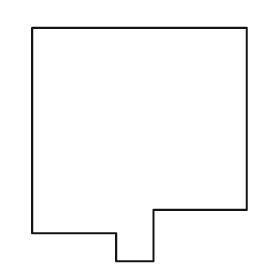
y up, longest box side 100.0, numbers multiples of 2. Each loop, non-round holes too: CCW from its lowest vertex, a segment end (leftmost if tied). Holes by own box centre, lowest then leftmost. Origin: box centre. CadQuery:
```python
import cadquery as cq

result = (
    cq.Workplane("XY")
    .moveTo(-10.0, -50.0)
    .lineTo(6.0, -50.0)
    .lineTo(6.0, -28.0)
    .lineTo(46.0, -28.0)
    .lineTo(46.0, 50.0)
    .lineTo(-46.0, 50.0)
    .lineTo(-46.0, -38.0)
    .lineTo(-10.0, -38.0)
    .close()
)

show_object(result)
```